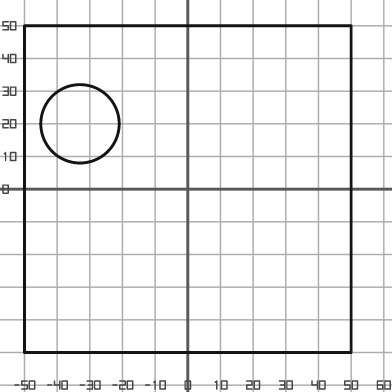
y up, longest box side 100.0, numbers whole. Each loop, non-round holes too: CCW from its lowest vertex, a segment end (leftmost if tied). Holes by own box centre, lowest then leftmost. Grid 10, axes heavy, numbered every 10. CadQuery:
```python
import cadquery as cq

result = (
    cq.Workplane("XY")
    .moveTo(-50.0, -50.0)
    .lineTo(50.0, -50.0)
    .lineTo(50.0, 50.0)
    .lineTo(-50.0, 50.0)
    .close()
    .moveTo(-33.0, 20.0)
    .circle(12.0)
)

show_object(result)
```